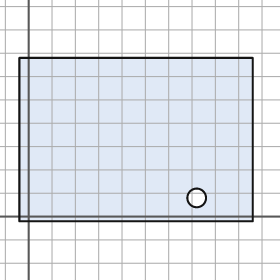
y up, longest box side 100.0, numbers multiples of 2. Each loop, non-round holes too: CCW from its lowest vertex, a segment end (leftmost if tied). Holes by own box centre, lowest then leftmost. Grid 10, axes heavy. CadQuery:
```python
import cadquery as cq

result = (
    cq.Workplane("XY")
    .moveTo(-4.0, -2.0)
    .lineTo(96.0, -2.0)
    .lineTo(96.0, 68.0)
    .lineTo(-4.0, 68.0)
    .close()
    .moveTo(72.0, 8.0)
    .circle(4.0)
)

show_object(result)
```